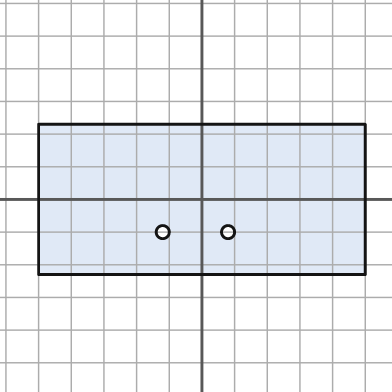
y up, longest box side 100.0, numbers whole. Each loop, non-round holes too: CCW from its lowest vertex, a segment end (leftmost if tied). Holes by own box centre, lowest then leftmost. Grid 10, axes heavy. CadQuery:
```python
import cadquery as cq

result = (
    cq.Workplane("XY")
    .moveTo(-50.0, -23.0)
    .lineTo(50.0, -23.0)
    .lineTo(50.0, 23.0)
    .lineTo(-50.0, 23.0)
    .close()
    .moveTo(-12.0, -10.0)
    .circle(2.0)
    .moveTo(8.0, -10.0)
    .circle(2.0)
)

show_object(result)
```